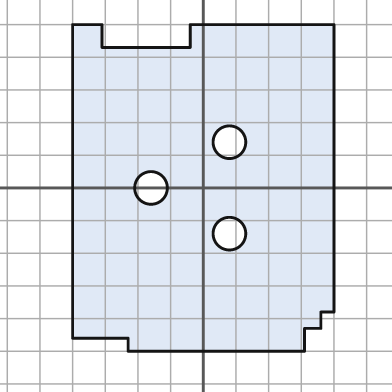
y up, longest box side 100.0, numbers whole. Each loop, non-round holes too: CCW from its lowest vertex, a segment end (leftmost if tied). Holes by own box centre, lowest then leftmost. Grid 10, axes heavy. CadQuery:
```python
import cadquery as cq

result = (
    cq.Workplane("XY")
    .moveTo(-23.0, -50.0)
    .lineTo(31.0, -50.0)
    .lineTo(31.0, -43.0)
    .lineTo(36.0, -43.0)
    .lineTo(36.0, -38.0)
    .lineTo(40.0, -38.0)
    .lineTo(40.0, 50.0)
    .lineTo(-4.0, 50.0)
    .lineTo(-4.0, 43.0)
    .lineTo(-31.0, 43.0)
    .lineTo(-31.0, 50.0)
    .lineTo(-40.0, 50.0)
    .lineTo(-40.0, -46.0)
    .lineTo(-23.0, -46.0)
    .close()
    .moveTo(8.0, -14.0)
    .circle(5.0)
    .moveTo(-16.0, 0.0)
    .circle(5.0)
    .moveTo(8.0, 14.0)
    .circle(5.0)
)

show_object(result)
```